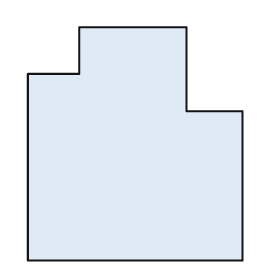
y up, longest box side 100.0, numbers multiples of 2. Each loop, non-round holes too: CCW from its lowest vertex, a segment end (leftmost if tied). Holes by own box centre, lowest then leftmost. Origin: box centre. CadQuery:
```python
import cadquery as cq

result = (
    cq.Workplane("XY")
    .moveTo(-46.0, -50.0)
    .lineTo(46.0, -50.0)
    .lineTo(46.0, 14.0)
    .lineTo(22.0, 14.0)
    .lineTo(22.0, 50.0)
    .lineTo(-24.0, 50.0)
    .lineTo(-24.0, 30.0)
    .lineTo(-46.0, 30.0)
    .close()
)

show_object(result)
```